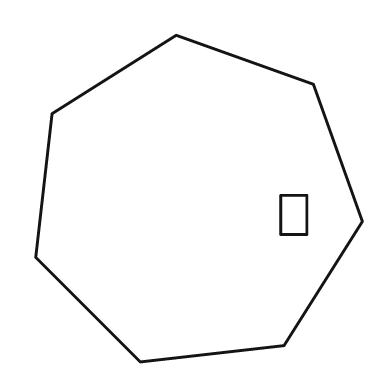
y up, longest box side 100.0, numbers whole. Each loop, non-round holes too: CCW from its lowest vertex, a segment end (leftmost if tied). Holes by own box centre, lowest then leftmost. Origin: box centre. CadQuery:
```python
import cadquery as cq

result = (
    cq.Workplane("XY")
    .moveTo(-18.0, -50.0)
    .lineTo(26.0, -45.0)
    .lineTo(50.0, -7.0)
    .lineTo(35.0, 35.0)
    .lineTo(-7.0, 50.0)
    .lineTo(-45.0, 26.0)
    .lineTo(-50.0, -18.0)
    .close()
    .moveTo(25.0, -11.0)
    .lineTo(33.0, -11.0)
    .lineTo(33.0, 1.0)
    .lineTo(25.0, 1.0)
    .close()
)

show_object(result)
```